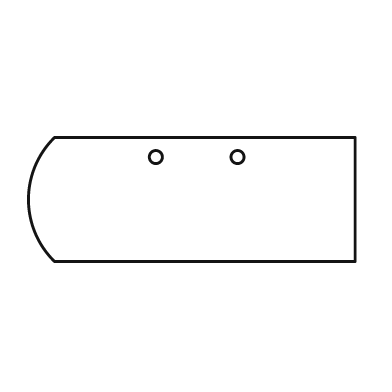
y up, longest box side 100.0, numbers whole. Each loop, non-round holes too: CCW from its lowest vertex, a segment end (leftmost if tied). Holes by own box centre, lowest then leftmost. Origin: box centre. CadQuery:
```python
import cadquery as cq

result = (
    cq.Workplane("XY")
    .moveTo(-42.0, -19.0)
    .lineTo(50.0, -19.0)
    .lineTo(50.0, 19.0)
    .lineTo(-42.0, 19.0)
    .threePointArc((-50.0, 0.0), (-42.0, -19.0))
    .close()
    .moveTo(-11.0, 13.0)
    .circle(2.0)
    .moveTo(14.0, 13.0)
    .circle(2.0)
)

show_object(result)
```